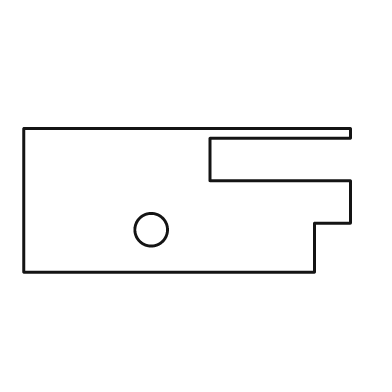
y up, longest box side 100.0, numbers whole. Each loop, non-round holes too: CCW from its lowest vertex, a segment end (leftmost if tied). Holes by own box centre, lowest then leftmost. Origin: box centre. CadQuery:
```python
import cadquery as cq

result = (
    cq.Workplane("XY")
    .moveTo(-50.0, -22.0)
    .lineTo(39.0, -22.0)
    .lineTo(39.0, -7.0)
    .lineTo(50.0, -7.0)
    .lineTo(50.0, 6.0)
    .lineTo(7.0, 6.0)
    .lineTo(7.0, 19.0)
    .lineTo(50.0, 19.0)
    .lineTo(50.0, 22.0)
    .lineTo(-50.0, 22.0)
    .close()
    .moveTo(-11.0, -9.0)
    .circle(5.0)
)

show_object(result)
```